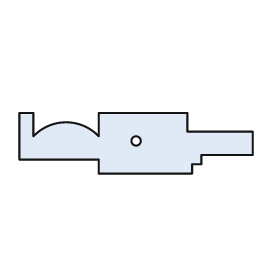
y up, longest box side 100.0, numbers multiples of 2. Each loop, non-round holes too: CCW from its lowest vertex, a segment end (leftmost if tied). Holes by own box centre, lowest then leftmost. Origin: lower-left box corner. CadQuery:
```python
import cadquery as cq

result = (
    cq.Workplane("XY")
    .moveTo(34.0, 0.0)
    .lineTo(74.0, 0.0)
    .lineTo(74.0, 4.0)
    .lineTo(78.0, 4.0)
    .lineTo(78.0, 8.0)
    .lineTo(100.0, 8.0)
    .lineTo(100.0, 18.0)
    .lineTo(72.0, 18.0)
    .lineTo(72.0, 26.0)
    .lineTo(34.0, 26.0)
    .lineTo(34.0, 16.0)
    .threePointArc((20.0, 22.0), (6.0, 16.0))
    .lineTo(6.0, 26.0)
    .lineTo(0.0, 26.0)
    .lineTo(0.0, 6.0)
    .lineTo(34.0, 6.0)
    .close()
    .moveTo(50.0, 14.0)
    .circle(2.0)
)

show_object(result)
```